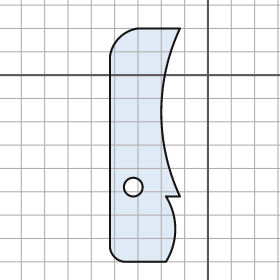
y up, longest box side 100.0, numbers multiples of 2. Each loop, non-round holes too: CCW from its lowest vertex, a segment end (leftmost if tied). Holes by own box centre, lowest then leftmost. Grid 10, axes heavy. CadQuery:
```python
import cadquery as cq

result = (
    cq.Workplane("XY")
    .moveTo(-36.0, -80.0)
    .lineTo(-18.0, -80.0)
    .threePointArc((-14.0, -66.0), (-18.0, -52.0))
    .lineTo(-12.0, -52.0)
    .threePointArc((-20.0, -16.0), (-12.0, 20.0))
    .lineTo(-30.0, 20.0)
    .threePointArc((-38.0, 16.0), (-42.0, 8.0))
    .lineTo(-42.0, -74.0)
    .threePointArc((-40.0, -78.0), (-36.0, -80.0))
    .close()
    .moveTo(-32.0, -48.0)
    .circle(4.0)
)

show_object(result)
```